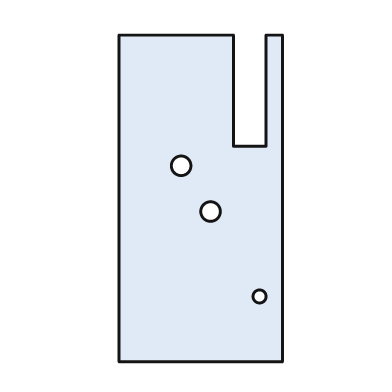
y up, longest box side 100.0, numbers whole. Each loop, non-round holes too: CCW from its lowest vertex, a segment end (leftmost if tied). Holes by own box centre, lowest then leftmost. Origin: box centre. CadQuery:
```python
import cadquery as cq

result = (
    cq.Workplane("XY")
    .moveTo(-25.0, -50.0)
    .lineTo(25.0, -50.0)
    .lineTo(25.0, 50.0)
    .lineTo(20.0, 50.0)
    .lineTo(20.0, 16.0)
    .lineTo(10.0, 16.0)
    .lineTo(10.0, 50.0)
    .lineTo(-25.0, 50.0)
    .close()
    .moveTo(18.0, -30.0)
    .circle(2.0)
    .moveTo(3.0, -4.0)
    .circle(3.0)
    .moveTo(-6.0, 10.0)
    .circle(3.0)
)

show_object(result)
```